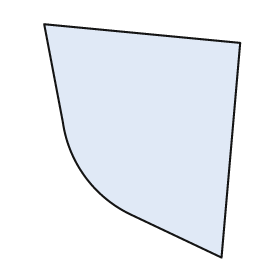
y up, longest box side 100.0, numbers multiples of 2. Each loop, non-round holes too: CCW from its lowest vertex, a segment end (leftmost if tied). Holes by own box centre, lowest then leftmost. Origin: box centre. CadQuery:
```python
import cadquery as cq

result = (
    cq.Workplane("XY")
    .moveTo(34.0, -50.0)
    .lineTo(42.0, 42.0)
    .lineTo(-42.0, 50.0)
    .lineTo(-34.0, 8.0)
    .threePointArc((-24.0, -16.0), (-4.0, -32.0))
    .close()
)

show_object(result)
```